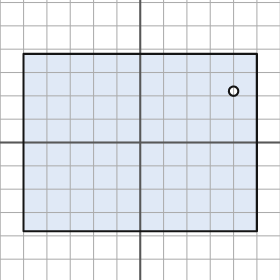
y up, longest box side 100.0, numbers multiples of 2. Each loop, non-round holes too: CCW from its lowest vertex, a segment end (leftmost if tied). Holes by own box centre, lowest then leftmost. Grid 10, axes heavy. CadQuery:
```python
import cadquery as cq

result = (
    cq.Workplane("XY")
    .moveTo(-50.0, -38.0)
    .lineTo(50.0, -38.0)
    .lineTo(50.0, 38.0)
    .lineTo(-50.0, 38.0)
    .close()
    .moveTo(40.0, 22.0)
    .circle(2.0)
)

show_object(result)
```